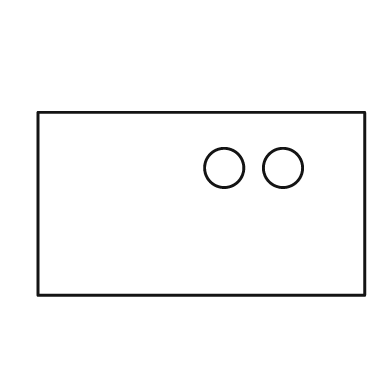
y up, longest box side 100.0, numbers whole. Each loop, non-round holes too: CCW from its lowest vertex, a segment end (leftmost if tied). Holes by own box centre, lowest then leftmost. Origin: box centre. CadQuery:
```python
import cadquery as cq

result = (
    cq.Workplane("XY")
    .moveTo(-50.0, -28.0)
    .lineTo(50.0, -28.0)
    .lineTo(50.0, 28.0)
    .lineTo(-50.0, 28.0)
    .close()
    .moveTo(7.0, 11.0)
    .circle(6.0)
    .moveTo(25.0, 11.0)
    .circle(6.0)
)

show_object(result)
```